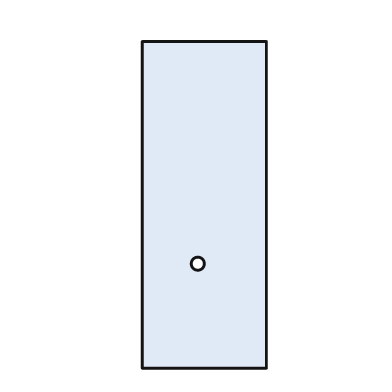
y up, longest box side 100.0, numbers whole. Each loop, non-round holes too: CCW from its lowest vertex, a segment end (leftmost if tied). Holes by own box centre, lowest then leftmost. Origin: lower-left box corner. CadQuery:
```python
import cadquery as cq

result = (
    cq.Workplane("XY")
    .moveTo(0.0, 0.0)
    .lineTo(38.0, 0.0)
    .lineTo(38.0, 100.0)
    .lineTo(0.0, 100.0)
    .close()
    .moveTo(17.0, 32.0)
    .circle(2.0)
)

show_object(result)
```